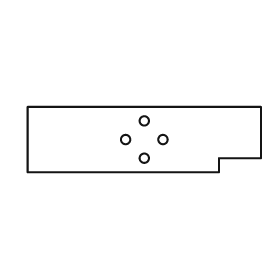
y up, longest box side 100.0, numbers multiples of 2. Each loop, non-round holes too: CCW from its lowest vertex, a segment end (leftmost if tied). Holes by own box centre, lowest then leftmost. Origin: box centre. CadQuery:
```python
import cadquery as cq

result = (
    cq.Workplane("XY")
    .moveTo(-50.0, -14.0)
    .lineTo(32.0, -14.0)
    .lineTo(32.0, -8.0)
    .lineTo(50.0, -8.0)
    .lineTo(50.0, 14.0)
    .lineTo(-50.0, 14.0)
    .close()
    .moveTo(0.0, -8.0)
    .circle(2.0)
    .moveTo(-8.0, 0.0)
    .circle(2.0)
    .moveTo(8.0, 0.0)
    .circle(2.0)
    .moveTo(0.0, 8.0)
    .circle(2.0)
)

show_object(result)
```